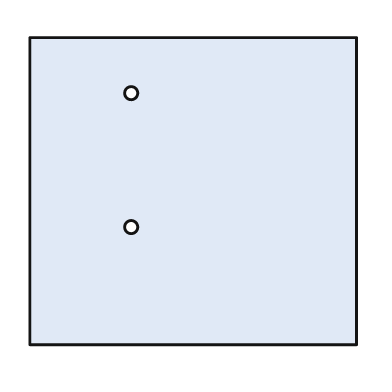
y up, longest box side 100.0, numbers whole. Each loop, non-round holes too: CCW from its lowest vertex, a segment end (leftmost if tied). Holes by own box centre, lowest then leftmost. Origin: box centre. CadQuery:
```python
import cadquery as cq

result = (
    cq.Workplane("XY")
    .moveTo(-50.0, -47.0)
    .lineTo(50.0, -47.0)
    .lineTo(50.0, 47.0)
    .lineTo(-50.0, 47.0)
    .close()
    .moveTo(-19.0, -11.0)
    .circle(2.0)
    .moveTo(-19.0, 30.0)
    .circle(2.0)
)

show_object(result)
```